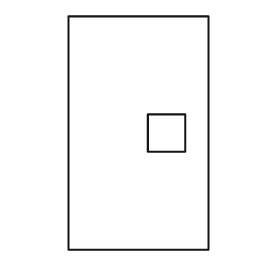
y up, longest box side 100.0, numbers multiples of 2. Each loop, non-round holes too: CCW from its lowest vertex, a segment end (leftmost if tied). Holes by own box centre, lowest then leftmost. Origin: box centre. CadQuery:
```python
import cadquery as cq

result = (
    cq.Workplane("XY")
    .moveTo(-30.0, -50.0)
    .lineTo(30.0, -50.0)
    .lineTo(30.0, 50.0)
    .lineTo(-30.0, 50.0)
    .close()
    .moveTo(4.0, -8.0)
    .lineTo(20.0, -8.0)
    .lineTo(20.0, 8.0)
    .lineTo(4.0, 8.0)
    .close()
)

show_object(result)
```